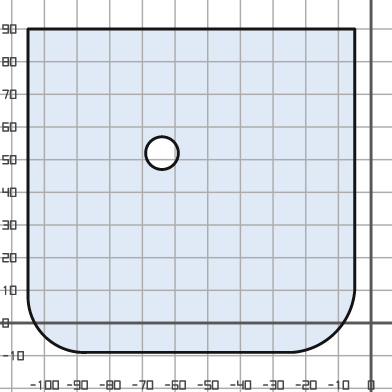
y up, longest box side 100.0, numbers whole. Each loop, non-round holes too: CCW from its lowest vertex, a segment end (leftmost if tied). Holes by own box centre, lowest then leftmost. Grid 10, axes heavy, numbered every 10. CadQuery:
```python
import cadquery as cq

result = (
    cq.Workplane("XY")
    .moveTo(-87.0, -9.0)
    .lineTo(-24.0, -9.0)
    .threePointArc((-11.0, -3.0), (-5.0, 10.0))
    .lineTo(-5.0, 90.0)
    .lineTo(-105.0, 90.0)
    .lineTo(-105.0, 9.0)
    .threePointArc((-100.0, -4.0), (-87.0, -9.0))
    .close()
    .moveTo(-64.0, 52.0)
    .circle(5.0)
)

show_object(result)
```